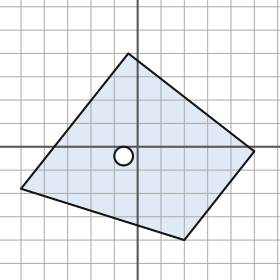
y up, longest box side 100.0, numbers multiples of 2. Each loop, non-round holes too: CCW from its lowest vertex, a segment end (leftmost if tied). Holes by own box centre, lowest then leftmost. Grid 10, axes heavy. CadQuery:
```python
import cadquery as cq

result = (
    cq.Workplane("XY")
    .moveTo(20.0, -40.0)
    .lineTo(50.0, -2.0)
    .lineTo(-4.0, 40.0)
    .lineTo(-50.0, -18.0)
    .close()
    .moveTo(-6.0, -4.0)
    .circle(4.0)
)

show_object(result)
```